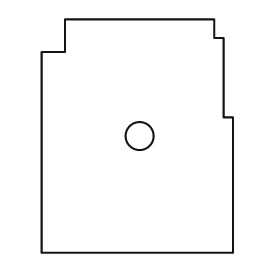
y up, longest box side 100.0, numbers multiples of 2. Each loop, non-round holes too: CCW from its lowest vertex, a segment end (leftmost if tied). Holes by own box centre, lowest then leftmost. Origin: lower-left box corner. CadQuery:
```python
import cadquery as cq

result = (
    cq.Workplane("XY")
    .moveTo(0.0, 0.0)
    .lineTo(82.0, 0.0)
    .lineTo(82.0, 58.0)
    .lineTo(78.0, 58.0)
    .lineTo(78.0, 92.0)
    .lineTo(74.0, 92.0)
    .lineTo(74.0, 100.0)
    .lineTo(10.0, 100.0)
    .lineTo(10.0, 86.0)
    .lineTo(0.0, 86.0)
    .close()
    .moveTo(42.0, 50.0)
    .circle(6.0)
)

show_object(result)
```